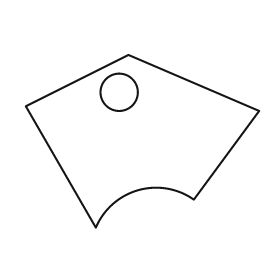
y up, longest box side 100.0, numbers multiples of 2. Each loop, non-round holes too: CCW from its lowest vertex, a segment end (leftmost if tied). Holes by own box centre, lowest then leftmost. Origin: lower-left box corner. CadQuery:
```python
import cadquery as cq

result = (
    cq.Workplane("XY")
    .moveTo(30.0, 0.0)
    .threePointArc((48.0, 16.0), (72.0, 12.0))
    .lineTo(100.0, 50.0)
    .lineTo(44.0, 74.0)
    .lineTo(0.0, 52.0)
    .close()
    .moveTo(40.0, 58.0)
    .circle(8.0)
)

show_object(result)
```